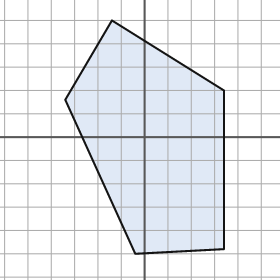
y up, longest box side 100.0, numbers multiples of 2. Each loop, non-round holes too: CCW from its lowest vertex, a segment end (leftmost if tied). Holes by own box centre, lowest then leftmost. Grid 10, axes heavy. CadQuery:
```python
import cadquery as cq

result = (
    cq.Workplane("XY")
    .moveTo(-4.0, -50.0)
    .lineTo(34.0, -48.0)
    .lineTo(34.0, 20.0)
    .lineTo(-14.0, 50.0)
    .lineTo(-34.0, 16.0)
    .close()
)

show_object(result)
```